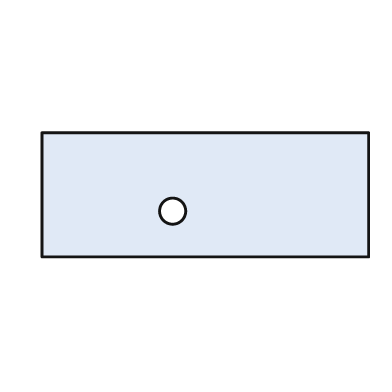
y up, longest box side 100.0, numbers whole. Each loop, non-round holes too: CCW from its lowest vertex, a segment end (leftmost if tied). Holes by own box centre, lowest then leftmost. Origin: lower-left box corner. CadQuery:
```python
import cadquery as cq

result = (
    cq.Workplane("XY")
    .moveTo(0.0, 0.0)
    .lineTo(100.0, 0.0)
    .lineTo(100.0, 38.0)
    .lineTo(0.0, 38.0)
    .close()
    .moveTo(40.0, 14.0)
    .circle(4.0)
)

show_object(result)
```